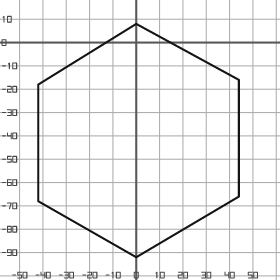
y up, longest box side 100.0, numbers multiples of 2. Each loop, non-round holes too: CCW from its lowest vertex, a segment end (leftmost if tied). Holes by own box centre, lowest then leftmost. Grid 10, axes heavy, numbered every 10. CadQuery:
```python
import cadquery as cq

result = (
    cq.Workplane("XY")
    .moveTo(0.0, -92.0)
    .lineTo(44.0, -66.0)
    .lineTo(44.0, -16.0)
    .lineTo(0.0, 8.0)
    .lineTo(-42.0, -18.0)
    .lineTo(-42.0, -68.0)
    .close()
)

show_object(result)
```